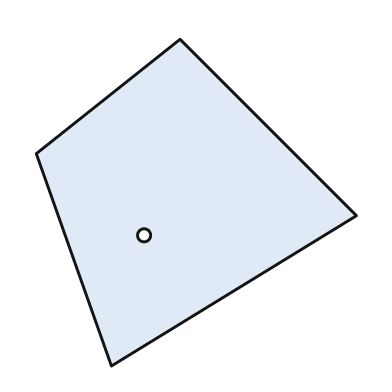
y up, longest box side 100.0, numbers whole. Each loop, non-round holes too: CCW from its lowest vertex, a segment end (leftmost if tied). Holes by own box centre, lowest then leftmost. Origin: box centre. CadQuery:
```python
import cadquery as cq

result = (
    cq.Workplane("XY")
    .moveTo(-26.0, -50.0)
    .lineTo(49.0, -4.0)
    .lineTo(-5.0, 50.0)
    .lineTo(-49.0, 15.0)
    .close()
    .moveTo(-16.0, -10.0)
    .circle(2.0)
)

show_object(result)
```